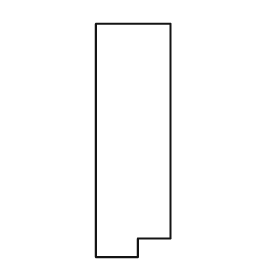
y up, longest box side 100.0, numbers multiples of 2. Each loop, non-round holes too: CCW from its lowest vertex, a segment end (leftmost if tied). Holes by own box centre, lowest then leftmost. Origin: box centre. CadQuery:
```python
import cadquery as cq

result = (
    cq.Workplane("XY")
    .moveTo(-16.0, -50.0)
    .lineTo(2.0, -50.0)
    .lineTo(2.0, -42.0)
    .lineTo(16.0, -42.0)
    .lineTo(16.0, 50.0)
    .lineTo(-16.0, 50.0)
    .close()
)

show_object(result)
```